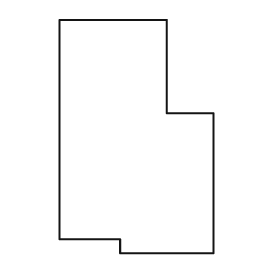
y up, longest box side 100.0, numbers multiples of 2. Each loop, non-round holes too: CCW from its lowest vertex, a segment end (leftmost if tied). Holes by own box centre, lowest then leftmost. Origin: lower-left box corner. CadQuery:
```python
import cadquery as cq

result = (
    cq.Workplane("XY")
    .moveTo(26.0, 0.0)
    .lineTo(66.0, 0.0)
    .lineTo(66.0, 60.0)
    .lineTo(46.0, 60.0)
    .lineTo(46.0, 100.0)
    .lineTo(0.0, 100.0)
    .lineTo(0.0, 6.0)
    .lineTo(26.0, 6.0)
    .close()
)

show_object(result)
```